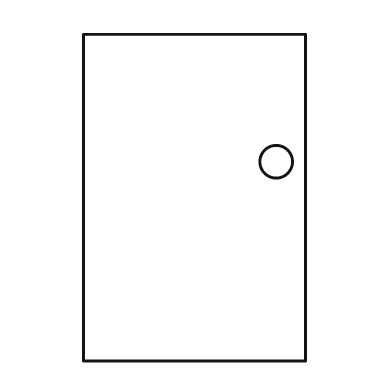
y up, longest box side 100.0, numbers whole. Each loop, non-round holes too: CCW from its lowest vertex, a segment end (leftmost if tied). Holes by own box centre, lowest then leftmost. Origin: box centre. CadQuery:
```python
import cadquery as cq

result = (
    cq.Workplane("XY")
    .moveTo(-34.0, -50.0)
    .lineTo(34.0, -50.0)
    .lineTo(34.0, 50.0)
    .lineTo(-34.0, 50.0)
    .close()
    .moveTo(25.0, 11.0)
    .circle(5.0)
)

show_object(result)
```